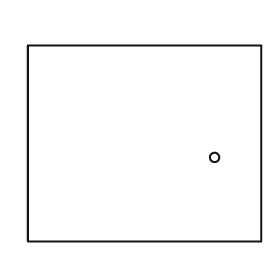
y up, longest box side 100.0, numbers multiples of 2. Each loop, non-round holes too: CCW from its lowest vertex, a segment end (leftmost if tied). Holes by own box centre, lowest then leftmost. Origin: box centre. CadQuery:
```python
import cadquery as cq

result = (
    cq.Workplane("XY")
    .moveTo(-50.0, -42.0)
    .lineTo(50.0, -42.0)
    .lineTo(50.0, 42.0)
    .lineTo(-50.0, 42.0)
    .close()
    .moveTo(30.0, -6.0)
    .circle(2.0)
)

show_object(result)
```